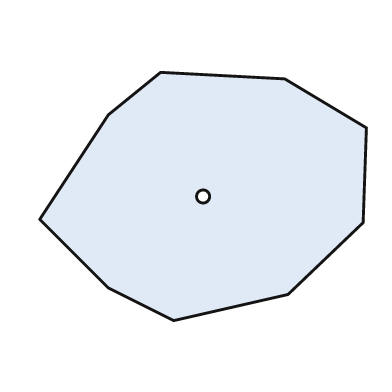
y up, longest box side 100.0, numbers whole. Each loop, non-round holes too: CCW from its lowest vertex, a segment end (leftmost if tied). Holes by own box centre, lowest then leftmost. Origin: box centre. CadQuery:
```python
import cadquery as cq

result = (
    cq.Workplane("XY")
    .moveTo(-9.0, -38.0)
    .lineTo(26.0, -30.0)
    .lineTo(49.0, -8.0)
    .lineTo(50.0, 21.0)
    .lineTo(25.0, 36.0)
    .lineTo(-13.0, 38.0)
    .lineTo(-29.0, 25.0)
    .lineTo(-50.0, -7.0)
    .lineTo(-29.0, -28.0)
    .close()
    .moveTo(0.0, 0.0)
    .circle(2.0)
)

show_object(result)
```